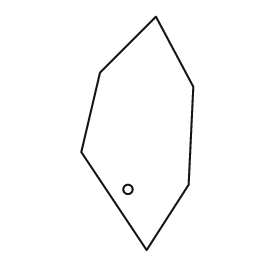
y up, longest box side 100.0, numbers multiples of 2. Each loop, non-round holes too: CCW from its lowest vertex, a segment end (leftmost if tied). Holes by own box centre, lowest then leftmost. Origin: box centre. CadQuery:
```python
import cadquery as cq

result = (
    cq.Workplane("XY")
    .moveTo(4.0, -50.0)
    .lineTo(22.0, -22.0)
    .lineTo(24.0, 20.0)
    .lineTo(8.0, 50.0)
    .lineTo(-16.0, 26.0)
    .lineTo(-24.0, -8.0)
    .close()
    .moveTo(-4.0, -24.0)
    .circle(2.0)
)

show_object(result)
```